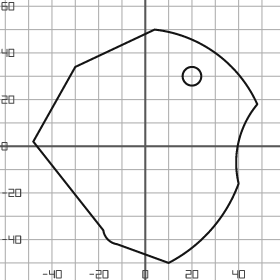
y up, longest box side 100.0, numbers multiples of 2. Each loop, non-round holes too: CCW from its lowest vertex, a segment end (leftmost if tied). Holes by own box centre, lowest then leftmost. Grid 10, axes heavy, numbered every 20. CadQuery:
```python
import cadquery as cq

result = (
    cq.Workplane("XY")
    .moveTo(10.0, -50.0)
    .threePointArc((28.0, -36.0), (40.0, -16.0))
    .threePointArc((40.0, 2.0), (48.0, 18.0))
    .threePointArc((30.0, 40.0), (4.0, 50.0))
    .lineTo(-30.0, 34.0)
    .lineTo(-48.0, 2.0)
    .lineTo(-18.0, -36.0)
    .threePointArc((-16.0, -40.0), (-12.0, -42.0))
    .close()
    .moveTo(20.0, 30.0)
    .circle(4.0)
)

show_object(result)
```